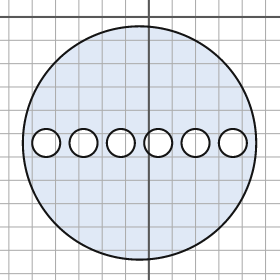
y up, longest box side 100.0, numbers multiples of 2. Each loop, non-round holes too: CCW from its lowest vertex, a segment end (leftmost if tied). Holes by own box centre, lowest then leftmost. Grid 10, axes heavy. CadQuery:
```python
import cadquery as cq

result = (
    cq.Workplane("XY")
    .moveTo(-4.0, -54.0)
    .circle(50.0)
    .moveTo(-44.0, -54.0)
    .circle(6.0)
    .moveTo(-28.0, -54.0)
    .circle(6.0)
    .moveTo(-12.0, -54.0)
    .circle(6.0)
    .moveTo(4.0, -54.0)
    .circle(6.0)
    .moveTo(20.0, -54.0)
    .circle(6.0)
    .moveTo(36.0, -54.0)
    .circle(6.0)
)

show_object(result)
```